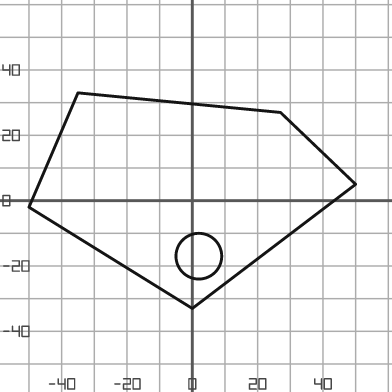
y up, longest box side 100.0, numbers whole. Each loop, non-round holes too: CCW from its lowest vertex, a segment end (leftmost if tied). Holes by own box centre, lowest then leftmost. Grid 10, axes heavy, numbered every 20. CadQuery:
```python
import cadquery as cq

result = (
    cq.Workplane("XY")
    .moveTo(0.0, -33.0)
    .lineTo(50.0, 5.0)
    .lineTo(27.0, 27.0)
    .lineTo(-35.0, 33.0)
    .lineTo(-50.0, -2.0)
    .close()
    .moveTo(2.0, -17.0)
    .circle(7.0)
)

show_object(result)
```